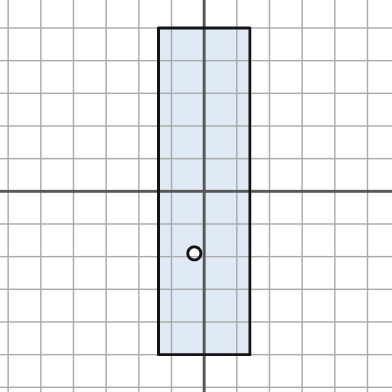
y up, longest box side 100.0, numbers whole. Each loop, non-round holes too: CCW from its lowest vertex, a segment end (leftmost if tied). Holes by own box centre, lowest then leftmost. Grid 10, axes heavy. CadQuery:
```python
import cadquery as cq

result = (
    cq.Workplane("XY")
    .moveTo(-14.0, -50.0)
    .lineTo(14.0, -50.0)
    .lineTo(14.0, 50.0)
    .lineTo(-14.0, 50.0)
    .close()
    .moveTo(-3.0, -19.0)
    .circle(2.0)
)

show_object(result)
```